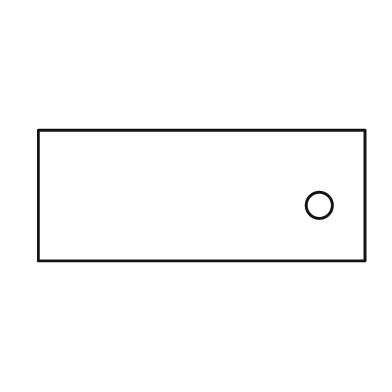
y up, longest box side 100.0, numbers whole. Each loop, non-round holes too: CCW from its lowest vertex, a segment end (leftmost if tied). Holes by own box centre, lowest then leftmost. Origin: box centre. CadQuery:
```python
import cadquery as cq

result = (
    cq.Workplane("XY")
    .moveTo(-50.0, -20.0)
    .lineTo(50.0, -20.0)
    .lineTo(50.0, 20.0)
    .lineTo(-50.0, 20.0)
    .close()
    .moveTo(36.0, -3.0)
    .circle(4.0)
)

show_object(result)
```